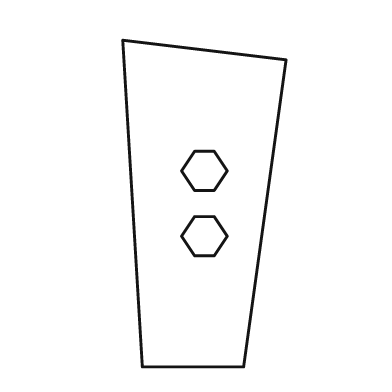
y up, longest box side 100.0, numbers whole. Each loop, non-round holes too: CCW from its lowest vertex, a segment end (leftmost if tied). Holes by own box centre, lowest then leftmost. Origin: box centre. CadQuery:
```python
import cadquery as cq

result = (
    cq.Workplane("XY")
    .moveTo(-19.0, -50.0)
    .lineTo(12.0, -50.0)
    .lineTo(25.0, 44.0)
    .lineTo(-25.0, 50.0)
    .close()
    .moveTo(-3.0, -16.0)
    .lineTo(3.0, -16.0)
    .lineTo(7.0, -10.0)
    .lineTo(3.0, -4.0)
    .lineTo(-3.0, -4.0)
    .lineTo(-7.0, -10.0)
    .close()
    .moveTo(-3.0, 4.0)
    .lineTo(3.0, 4.0)
    .lineTo(7.0, 10.0)
    .lineTo(3.0, 16.0)
    .lineTo(-3.0, 16.0)
    .lineTo(-7.0, 10.0)
    .close()
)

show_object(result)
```